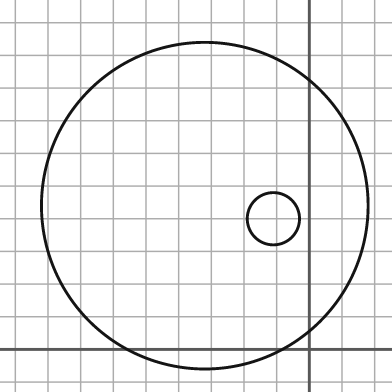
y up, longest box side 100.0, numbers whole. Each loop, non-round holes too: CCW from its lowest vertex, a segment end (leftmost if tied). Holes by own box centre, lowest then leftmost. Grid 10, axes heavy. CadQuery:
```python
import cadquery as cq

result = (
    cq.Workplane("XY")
    .moveTo(-32.0, 44.0)
    .circle(50.0)
    .moveTo(-11.0, 40.0)
    .circle(8.0)
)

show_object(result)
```